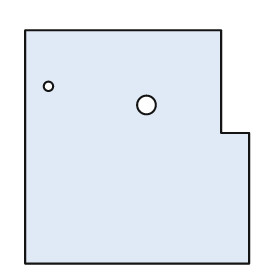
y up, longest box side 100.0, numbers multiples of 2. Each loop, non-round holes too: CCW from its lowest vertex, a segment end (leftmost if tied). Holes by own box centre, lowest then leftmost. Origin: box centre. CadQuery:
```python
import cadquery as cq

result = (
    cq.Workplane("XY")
    .moveTo(-48.0, -50.0)
    .lineTo(48.0, -50.0)
    .lineTo(48.0, 6.0)
    .lineTo(36.0, 6.0)
    .lineTo(36.0, 50.0)
    .lineTo(-48.0, 50.0)
    .close()
    .moveTo(4.0, 18.0)
    .circle(4.0)
    .moveTo(-38.0, 26.0)
    .circle(2.0)
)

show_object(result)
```